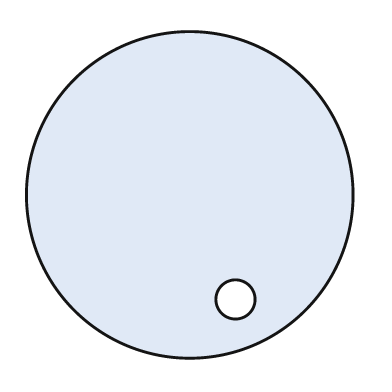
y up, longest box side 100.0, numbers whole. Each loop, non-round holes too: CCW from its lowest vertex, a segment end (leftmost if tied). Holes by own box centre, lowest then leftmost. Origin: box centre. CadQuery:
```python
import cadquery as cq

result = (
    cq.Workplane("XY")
    .moveTo(0.0, 0.0)
    .circle(50.0)
    .moveTo(14.0, -32.0)
    .circle(6.0)
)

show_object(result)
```